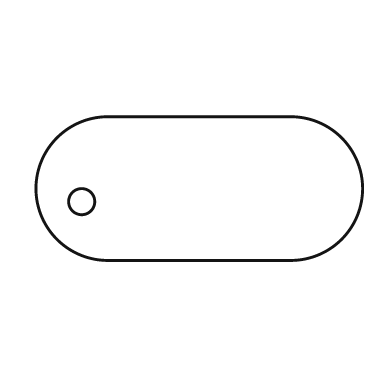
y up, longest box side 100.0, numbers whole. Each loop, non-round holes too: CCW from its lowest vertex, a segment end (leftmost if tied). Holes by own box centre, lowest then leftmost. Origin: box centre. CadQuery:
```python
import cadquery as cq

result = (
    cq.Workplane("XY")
    .moveTo(-28.0, -22.0)
    .lineTo(28.0, -22.0)
    .threePointArc((50.0, 0.0), (28.0, 22.0))
    .lineTo(-28.0, 22.0)
    .threePointArc((-50.0, 0.0), (-28.0, -22.0))
    .close()
    .moveTo(-36.0, -4.0)
    .circle(4.0)
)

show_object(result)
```